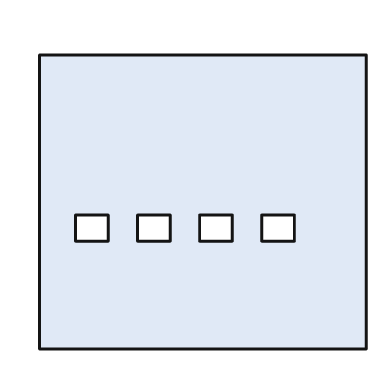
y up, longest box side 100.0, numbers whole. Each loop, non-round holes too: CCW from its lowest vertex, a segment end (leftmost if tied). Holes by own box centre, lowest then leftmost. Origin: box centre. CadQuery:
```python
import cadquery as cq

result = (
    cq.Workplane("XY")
    .moveTo(-50.0, -45.0)
    .lineTo(50.0, -45.0)
    .lineTo(50.0, 45.0)
    .lineTo(-50.0, 45.0)
    .close()
    .moveTo(-39.0, -12.0)
    .lineTo(-29.0, -12.0)
    .lineTo(-29.0, -4.0)
    .lineTo(-39.0, -4.0)
    .close()
    .moveTo(-20.0, -12.0)
    .lineTo(-10.0, -12.0)
    .lineTo(-10.0, -4.0)
    .lineTo(-20.0, -4.0)
    .close()
    .moveTo(-1.0, -12.0)
    .lineTo(9.0, -12.0)
    .lineTo(9.0, -4.0)
    .lineTo(-1.0, -4.0)
    .close()
    .moveTo(18.0, -12.0)
    .lineTo(28.0, -12.0)
    .lineTo(28.0, -4.0)
    .lineTo(18.0, -4.0)
    .close()
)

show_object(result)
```